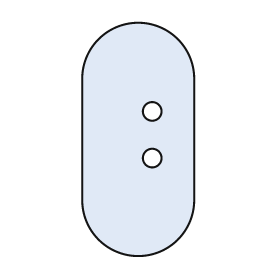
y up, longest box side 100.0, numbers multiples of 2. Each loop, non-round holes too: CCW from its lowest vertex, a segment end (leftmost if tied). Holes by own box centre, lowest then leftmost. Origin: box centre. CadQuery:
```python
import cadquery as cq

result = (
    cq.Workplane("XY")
    .moveTo(-24.0, -26.0)
    .threePointArc((0.0, -50.0), (24.0, -26.0))
    .lineTo(24.0, 26.0)
    .threePointArc((0.0, 50.0), (-24.0, 26.0))
    .close()
    .moveTo(6.0, -8.0)
    .circle(4.0)
    .moveTo(6.0, 12.0)
    .circle(4.0)
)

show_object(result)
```